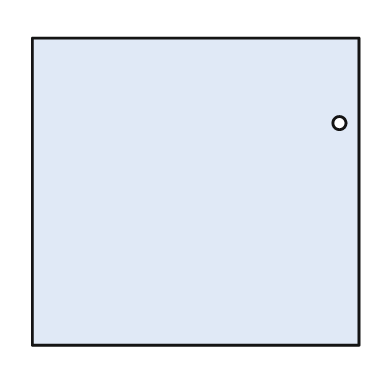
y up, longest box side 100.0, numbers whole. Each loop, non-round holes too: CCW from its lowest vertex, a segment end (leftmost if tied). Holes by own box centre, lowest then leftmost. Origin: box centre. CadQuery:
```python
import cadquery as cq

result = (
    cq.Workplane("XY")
    .moveTo(-50.0, -47.0)
    .lineTo(50.0, -47.0)
    .lineTo(50.0, 47.0)
    .lineTo(-50.0, 47.0)
    .close()
    .moveTo(44.0, 21.0)
    .circle(2.0)
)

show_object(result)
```